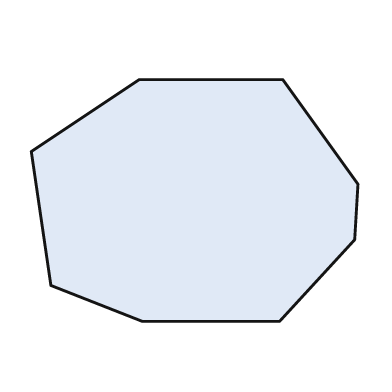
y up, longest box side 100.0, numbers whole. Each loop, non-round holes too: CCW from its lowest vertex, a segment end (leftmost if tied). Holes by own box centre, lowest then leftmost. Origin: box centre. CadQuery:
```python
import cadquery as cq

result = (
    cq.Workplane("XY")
    .moveTo(-16.0, -37.0)
    .lineTo(26.0, -37.0)
    .lineTo(49.0, -12.0)
    .lineTo(50.0, 5.0)
    .lineTo(27.0, 37.0)
    .lineTo(-17.0, 37.0)
    .lineTo(-50.0, 15.0)
    .lineTo(-44.0, -26.0)
    .close()
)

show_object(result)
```